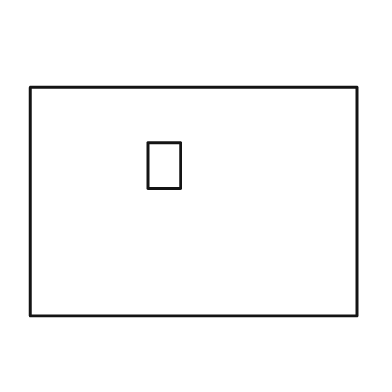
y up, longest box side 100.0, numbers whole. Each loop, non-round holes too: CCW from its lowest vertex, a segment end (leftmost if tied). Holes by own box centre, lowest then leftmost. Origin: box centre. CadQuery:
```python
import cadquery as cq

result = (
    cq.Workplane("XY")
    .moveTo(-50.0, -35.0)
    .lineTo(50.0, -35.0)
    .lineTo(50.0, 35.0)
    .lineTo(-50.0, 35.0)
    .close()
    .moveTo(-14.0, 4.0)
    .lineTo(-4.0, 4.0)
    .lineTo(-4.0, 18.0)
    .lineTo(-14.0, 18.0)
    .close()
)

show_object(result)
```